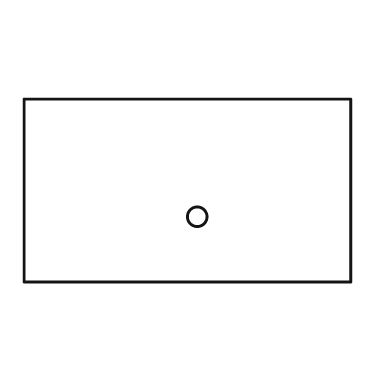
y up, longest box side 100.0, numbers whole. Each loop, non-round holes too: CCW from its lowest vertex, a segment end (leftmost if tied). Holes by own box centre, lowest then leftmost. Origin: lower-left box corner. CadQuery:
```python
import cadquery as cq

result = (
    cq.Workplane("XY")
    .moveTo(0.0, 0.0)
    .lineTo(100.0, 0.0)
    .lineTo(100.0, 56.0)
    .lineTo(0.0, 56.0)
    .close()
    .moveTo(53.0, 20.0)
    .circle(3.0)
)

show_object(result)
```